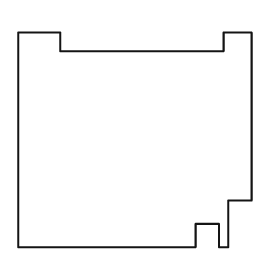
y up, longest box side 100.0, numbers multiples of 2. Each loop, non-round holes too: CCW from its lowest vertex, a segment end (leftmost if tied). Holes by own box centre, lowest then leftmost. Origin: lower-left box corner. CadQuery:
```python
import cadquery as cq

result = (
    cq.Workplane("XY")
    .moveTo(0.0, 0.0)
    .lineTo(76.0, 0.0)
    .lineTo(76.0, 10.0)
    .lineTo(86.0, 10.0)
    .lineTo(86.0, 0.0)
    .lineTo(90.0, 0.0)
    .lineTo(90.0, 20.0)
    .lineTo(100.0, 20.0)
    .lineTo(100.0, 92.0)
    .lineTo(88.0, 92.0)
    .lineTo(88.0, 84.0)
    .lineTo(18.0, 84.0)
    .lineTo(18.0, 92.0)
    .lineTo(0.0, 92.0)
    .close()
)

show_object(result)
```